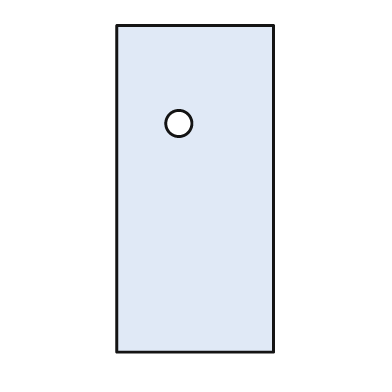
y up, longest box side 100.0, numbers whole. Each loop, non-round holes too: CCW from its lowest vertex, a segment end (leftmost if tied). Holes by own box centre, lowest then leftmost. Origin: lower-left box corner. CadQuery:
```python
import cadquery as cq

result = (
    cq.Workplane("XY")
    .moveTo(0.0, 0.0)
    .lineTo(48.0, 0.0)
    .lineTo(48.0, 100.0)
    .lineTo(0.0, 100.0)
    .close()
    .moveTo(19.0, 70.0)
    .circle(4.0)
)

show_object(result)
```